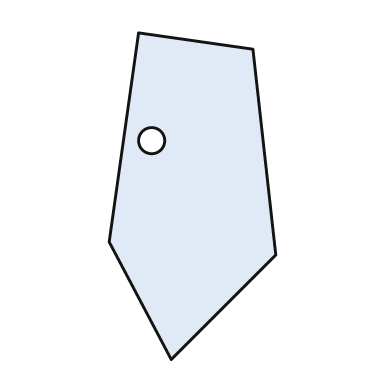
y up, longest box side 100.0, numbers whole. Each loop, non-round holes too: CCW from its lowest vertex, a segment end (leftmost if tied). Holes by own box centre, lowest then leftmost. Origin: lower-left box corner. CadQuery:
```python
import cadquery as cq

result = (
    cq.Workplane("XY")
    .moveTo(19.0, 0.0)
    .lineTo(51.0, 32.0)
    .lineTo(44.0, 95.0)
    .lineTo(9.0, 100.0)
    .lineTo(0.0, 36.0)
    .close()
    .moveTo(13.0, 67.0)
    .circle(4.0)
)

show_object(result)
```